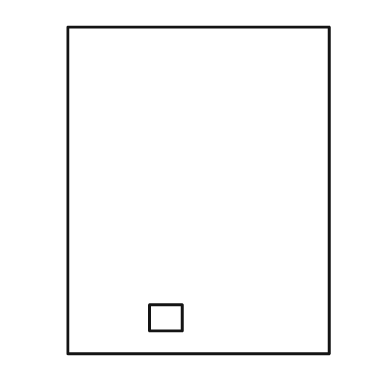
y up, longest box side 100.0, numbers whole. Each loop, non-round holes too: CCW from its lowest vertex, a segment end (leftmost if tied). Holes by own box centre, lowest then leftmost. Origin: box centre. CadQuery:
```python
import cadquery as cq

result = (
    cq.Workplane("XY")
    .moveTo(-40.0, -50.0)
    .lineTo(40.0, -50.0)
    .lineTo(40.0, 50.0)
    .lineTo(-40.0, 50.0)
    .close()
    .moveTo(-15.0, -43.0)
    .lineTo(-5.0, -43.0)
    .lineTo(-5.0, -35.0)
    .lineTo(-15.0, -35.0)
    .close()
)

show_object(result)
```